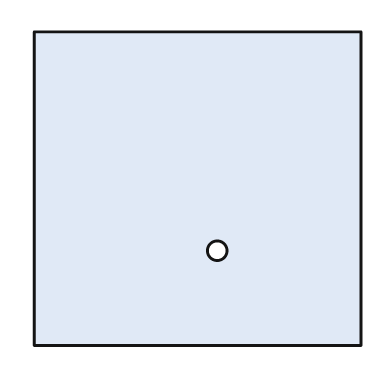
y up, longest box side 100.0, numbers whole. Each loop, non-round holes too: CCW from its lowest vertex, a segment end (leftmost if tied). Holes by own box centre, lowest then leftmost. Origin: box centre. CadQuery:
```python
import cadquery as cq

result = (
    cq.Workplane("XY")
    .moveTo(-50.0, -48.0)
    .lineTo(50.0, -48.0)
    .lineTo(50.0, 48.0)
    .lineTo(-50.0, 48.0)
    .close()
    .moveTo(6.0, -19.0)
    .circle(3.0)
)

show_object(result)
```